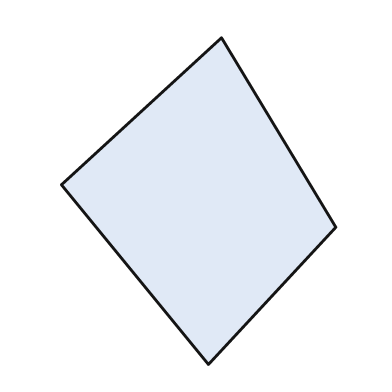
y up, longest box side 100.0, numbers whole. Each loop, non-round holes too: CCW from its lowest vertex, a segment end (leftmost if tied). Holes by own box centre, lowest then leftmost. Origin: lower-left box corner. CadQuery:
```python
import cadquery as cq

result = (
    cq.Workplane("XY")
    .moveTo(45.0, 0.0)
    .lineTo(84.0, 42.0)
    .lineTo(49.0, 100.0)
    .lineTo(0.0, 55.0)
    .close()
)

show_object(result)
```